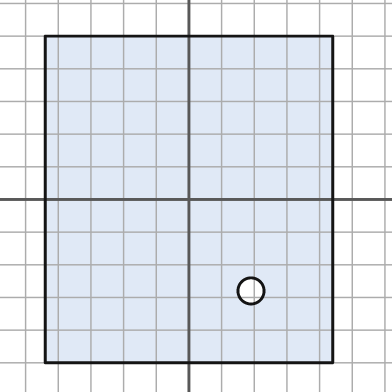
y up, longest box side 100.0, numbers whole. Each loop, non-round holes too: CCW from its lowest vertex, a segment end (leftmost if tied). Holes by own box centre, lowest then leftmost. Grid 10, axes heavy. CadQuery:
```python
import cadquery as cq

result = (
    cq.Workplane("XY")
    .moveTo(-44.0, -50.0)
    .lineTo(44.0, -50.0)
    .lineTo(44.0, 50.0)
    .lineTo(-44.0, 50.0)
    .close()
    .moveTo(19.0, -28.0)
    .circle(4.0)
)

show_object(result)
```